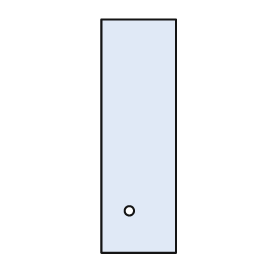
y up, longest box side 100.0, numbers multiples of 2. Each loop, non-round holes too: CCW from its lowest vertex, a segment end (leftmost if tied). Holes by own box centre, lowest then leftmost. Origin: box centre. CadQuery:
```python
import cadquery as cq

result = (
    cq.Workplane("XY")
    .moveTo(-16.0, -50.0)
    .lineTo(16.0, -50.0)
    .lineTo(16.0, 50.0)
    .lineTo(-16.0, 50.0)
    .close()
    .moveTo(-4.0, -32.0)
    .circle(2.0)
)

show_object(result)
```